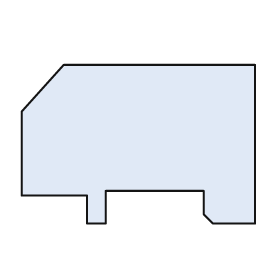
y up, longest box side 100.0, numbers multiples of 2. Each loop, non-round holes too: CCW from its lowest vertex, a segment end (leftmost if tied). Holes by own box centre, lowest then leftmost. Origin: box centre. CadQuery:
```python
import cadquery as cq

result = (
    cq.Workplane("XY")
    .moveTo(-22.0, -34.0)
    .lineTo(-14.0, -34.0)
    .lineTo(-14.0, -20.0)
    .lineTo(28.0, -20.0)
    .lineTo(28.0, -30.0)
    .lineTo(32.0, -34.0)
    .lineTo(50.0, -34.0)
    .lineTo(50.0, 34.0)
    .lineTo(-32.0, 34.0)
    .lineTo(-50.0, 14.0)
    .lineTo(-50.0, -22.0)
    .lineTo(-22.0, -22.0)
    .close()
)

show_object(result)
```